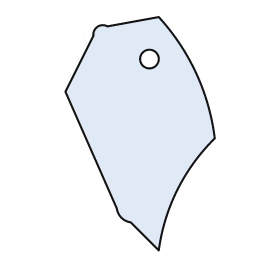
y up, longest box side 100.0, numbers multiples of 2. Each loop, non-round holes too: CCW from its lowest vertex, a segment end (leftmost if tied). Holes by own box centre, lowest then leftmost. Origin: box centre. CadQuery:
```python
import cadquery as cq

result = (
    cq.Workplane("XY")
    .moveTo(8.0, -50.0)
    .threePointArc((16.0, -24.0), (32.0, -2.0))
    .threePointArc((24.0, 26.0), (8.0, 50.0))
    .lineTo(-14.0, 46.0)
    .threePointArc((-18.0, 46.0), (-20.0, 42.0))
    .lineTo(-32.0, 18.0)
    .lineTo(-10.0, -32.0)
    .threePointArc((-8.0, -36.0), (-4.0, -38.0))
    .close()
    .moveTo(4.0, 32.0)
    .circle(4.0)
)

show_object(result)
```